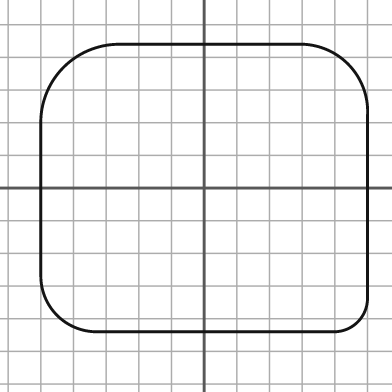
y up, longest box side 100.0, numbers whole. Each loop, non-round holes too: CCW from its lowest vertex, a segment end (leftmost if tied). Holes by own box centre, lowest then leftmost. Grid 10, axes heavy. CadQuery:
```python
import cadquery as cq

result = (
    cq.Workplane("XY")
    .moveTo(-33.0, -44.0)
    .lineTo(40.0, -44.0)
    .threePointArc((47.0, -41.0), (50.0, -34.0))
    .lineTo(50.0, 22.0)
    .threePointArc((44.0, 38.0), (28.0, 44.0))
    .lineTo(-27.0, 44.0)
    .threePointArc((-43.0, 37.0), (-50.0, 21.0))
    .lineTo(-50.0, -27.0)
    .threePointArc((-45.0, -39.0), (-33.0, -44.0))
    .close()
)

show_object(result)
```